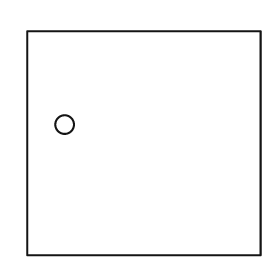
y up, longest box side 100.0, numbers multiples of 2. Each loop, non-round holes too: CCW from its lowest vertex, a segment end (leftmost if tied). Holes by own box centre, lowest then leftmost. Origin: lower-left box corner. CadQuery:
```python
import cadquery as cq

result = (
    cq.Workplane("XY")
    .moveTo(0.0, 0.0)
    .lineTo(100.0, 0.0)
    .lineTo(100.0, 96.0)
    .lineTo(0.0, 96.0)
    .close()
    .moveTo(16.0, 56.0)
    .circle(4.0)
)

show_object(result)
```